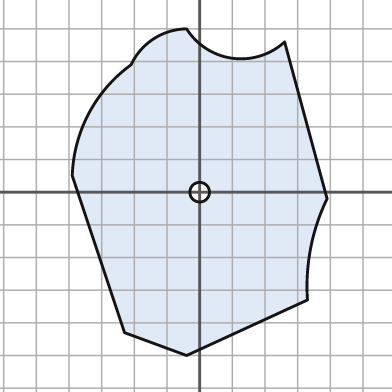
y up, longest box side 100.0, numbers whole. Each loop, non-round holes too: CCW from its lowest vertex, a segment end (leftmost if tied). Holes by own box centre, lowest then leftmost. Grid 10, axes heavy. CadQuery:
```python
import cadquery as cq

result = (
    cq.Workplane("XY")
    .moveTo(-4.0, -50.0)
    .lineTo(33.0, -33.0)
    .threePointArc((34.0, -17.0), (39.0, -2.0))
    .lineTo(26.0, 46.0)
    .threePointArc((10.0, 41.0), (-4.0, 50.0))
    .threePointArc((-14.0, 47.0), (-21.0, 39.0))
    .threePointArc((-34.0, 24.0), (-39.0, 5.0))
    .lineTo(-23.0, -43.0)
    .close()
    .moveTo(0.0, 0.0)
    .circle(3.0)
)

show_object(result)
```